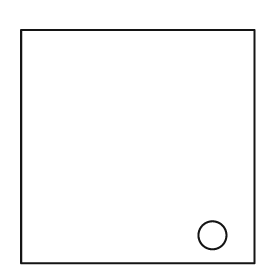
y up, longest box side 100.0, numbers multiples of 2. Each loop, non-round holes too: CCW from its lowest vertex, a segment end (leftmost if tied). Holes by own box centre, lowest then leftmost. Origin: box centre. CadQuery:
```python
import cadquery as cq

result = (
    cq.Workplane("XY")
    .moveTo(-50.0, -50.0)
    .lineTo(50.0, -50.0)
    .lineTo(50.0, 50.0)
    .lineTo(-50.0, 50.0)
    .close()
    .moveTo(32.0, -38.0)
    .circle(6.0)
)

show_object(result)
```